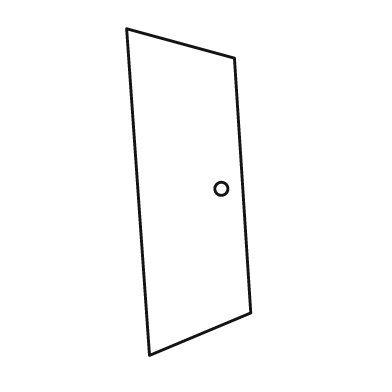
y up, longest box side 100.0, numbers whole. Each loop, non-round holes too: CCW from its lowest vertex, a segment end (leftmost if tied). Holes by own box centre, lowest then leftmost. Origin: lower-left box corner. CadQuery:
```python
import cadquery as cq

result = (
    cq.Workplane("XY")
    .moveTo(7.0, 0.0)
    .lineTo(38.0, 13.0)
    .lineTo(33.0, 91.0)
    .lineTo(0.0, 100.0)
    .close()
    .moveTo(29.0, 51.0)
    .circle(2.0)
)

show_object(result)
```